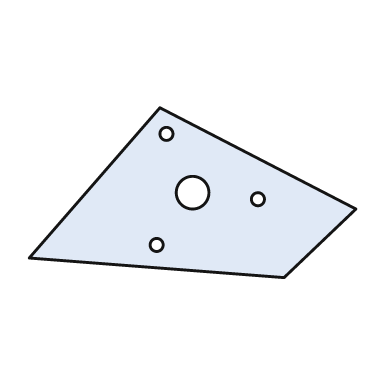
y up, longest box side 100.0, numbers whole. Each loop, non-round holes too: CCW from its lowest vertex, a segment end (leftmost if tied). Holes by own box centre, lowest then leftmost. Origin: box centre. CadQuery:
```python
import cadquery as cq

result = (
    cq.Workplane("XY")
    .moveTo(28.0, -26.0)
    .lineTo(50.0, -5.0)
    .lineTo(-10.0, 26.0)
    .lineTo(-50.0, -20.0)
    .close()
    .moveTo(-11.0, -16.0)
    .circle(2.0)
    .moveTo(20.0, -2.0)
    .circle(2.0)
    .moveTo(0.0, 0.0)
    .circle(5.0)
    .moveTo(-8.0, 18.0)
    .circle(2.0)
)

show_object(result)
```